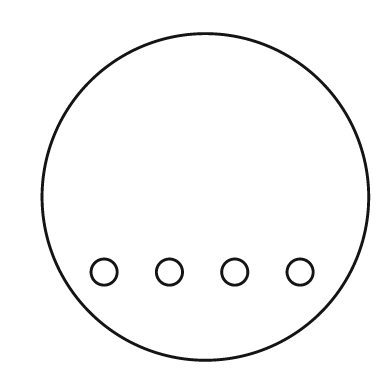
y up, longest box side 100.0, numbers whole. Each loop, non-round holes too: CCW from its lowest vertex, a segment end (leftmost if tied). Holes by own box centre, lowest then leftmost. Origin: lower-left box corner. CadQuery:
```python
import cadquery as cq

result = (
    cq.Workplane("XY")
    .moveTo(50.0, 50.0)
    .circle(50.0)
    .moveTo(19.0, 27.0)
    .circle(4.0)
    .moveTo(39.0, 27.0)
    .circle(4.0)
    .moveTo(59.0, 27.0)
    .circle(4.0)
    .moveTo(79.0, 27.0)
    .circle(4.0)
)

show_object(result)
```